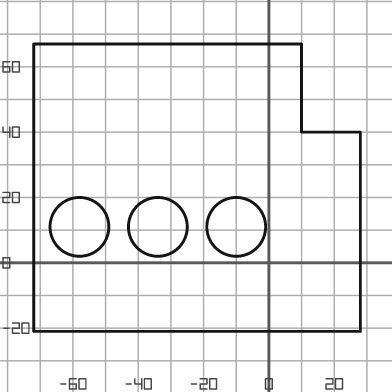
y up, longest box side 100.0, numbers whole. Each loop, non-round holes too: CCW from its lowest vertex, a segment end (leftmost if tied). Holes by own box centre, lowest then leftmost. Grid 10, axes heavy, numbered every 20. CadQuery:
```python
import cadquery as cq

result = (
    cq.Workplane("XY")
    .moveTo(-72.0, -21.0)
    .lineTo(28.0, -21.0)
    .lineTo(28.0, 40.0)
    .lineTo(10.0, 40.0)
    .lineTo(10.0, 67.0)
    .lineTo(-72.0, 67.0)
    .close()
    .moveTo(-58.0, 11.0)
    .circle(9.0)
    .moveTo(-34.0, 11.0)
    .circle(9.0)
    .moveTo(-10.0, 11.0)
    .circle(9.0)
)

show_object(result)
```